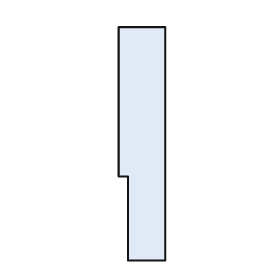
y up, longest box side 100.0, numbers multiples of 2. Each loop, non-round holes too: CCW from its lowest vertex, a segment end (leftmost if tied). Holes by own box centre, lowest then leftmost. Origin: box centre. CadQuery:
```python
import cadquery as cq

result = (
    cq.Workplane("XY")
    .moveTo(-6.0, -50.0)
    .lineTo(10.0, -50.0)
    .lineTo(10.0, 50.0)
    .lineTo(-10.0, 50.0)
    .lineTo(-10.0, -14.0)
    .lineTo(-6.0, -14.0)
    .close()
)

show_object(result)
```